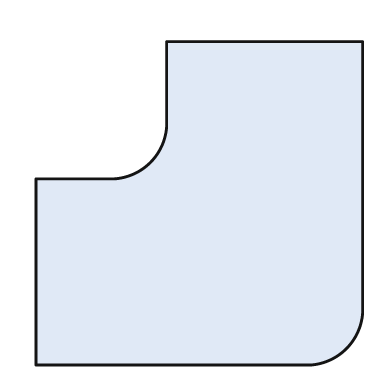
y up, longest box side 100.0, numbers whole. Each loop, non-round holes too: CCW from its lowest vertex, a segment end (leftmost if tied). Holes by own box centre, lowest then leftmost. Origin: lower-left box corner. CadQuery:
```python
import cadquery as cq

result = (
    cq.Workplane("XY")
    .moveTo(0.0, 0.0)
    .lineTo(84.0, 0.0)
    .threePointArc((95.0, 5.0), (100.0, 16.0))
    .lineTo(100.0, 99.0)
    .lineTo(40.0, 99.0)
    .lineTo(40.0, 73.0)
    .threePointArc((35.0, 62.0), (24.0, 57.0))
    .lineTo(0.0, 57.0)
    .close()
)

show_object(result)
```